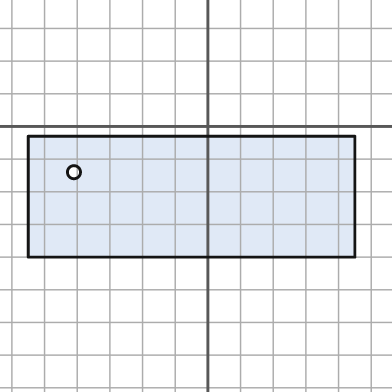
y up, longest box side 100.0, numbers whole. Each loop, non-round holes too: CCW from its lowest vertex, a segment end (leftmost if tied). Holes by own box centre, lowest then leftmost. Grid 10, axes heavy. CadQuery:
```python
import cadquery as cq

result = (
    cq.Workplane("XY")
    .moveTo(-55.0, -40.0)
    .lineTo(45.0, -40.0)
    .lineTo(45.0, -3.0)
    .lineTo(-55.0, -3.0)
    .close()
    .moveTo(-41.0, -14.0)
    .circle(2.0)
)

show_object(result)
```